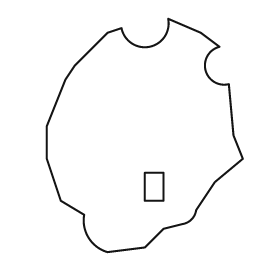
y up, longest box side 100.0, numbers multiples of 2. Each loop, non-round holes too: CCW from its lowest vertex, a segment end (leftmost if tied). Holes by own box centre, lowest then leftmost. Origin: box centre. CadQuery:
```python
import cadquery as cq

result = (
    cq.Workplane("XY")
    .moveTo(-16.0, -50.0)
    .lineTo(0.0, -48.0)
    .lineTo(8.0, -40.0)
    .lineTo(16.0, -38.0)
    .threePointArc((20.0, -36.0), (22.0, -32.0))
    .lineTo(30.0, -20.0)
    .lineTo(42.0, -10.0)
    .lineTo(38.0, 0.0)
    .lineTo(36.0, 22.0)
    .threePointArc((26.0, 28.0), (32.0, 38.0))
    .lineTo(24.0, 44.0)
    .lineTo(10.0, 50.0)
    .threePointArc((2.0, 38.0), (-10.0, 46.0))
    .lineTo(-16.0, 44.0)
    .lineTo(-30.0, 30.0)
    .lineTo(-34.0, 24.0)
    .lineTo(-42.0, 4.0)
    .lineTo(-42.0, -10.0)
    .lineTo(-36.0, -28.0)
    .lineTo(-26.0, -34.0)
    .threePointArc((-24.0, -44.0), (-16.0, -50.0))
    .close()
    .moveTo(0.0, -28.0)
    .lineTo(8.0, -28.0)
    .lineTo(8.0, -16.0)
    .lineTo(0.0, -16.0)
    .close()
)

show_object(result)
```